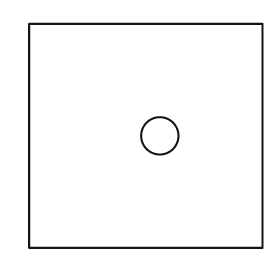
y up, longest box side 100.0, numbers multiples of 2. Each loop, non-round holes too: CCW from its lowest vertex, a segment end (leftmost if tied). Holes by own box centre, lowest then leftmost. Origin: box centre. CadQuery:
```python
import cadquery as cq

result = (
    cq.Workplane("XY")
    .moveTo(-50.0, -48.0)
    .lineTo(50.0, -48.0)
    .lineTo(50.0, 48.0)
    .lineTo(-50.0, 48.0)
    .close()
    .moveTo(6.0, 0.0)
    .circle(8.0)
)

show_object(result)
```